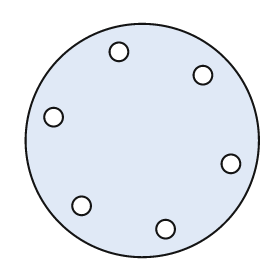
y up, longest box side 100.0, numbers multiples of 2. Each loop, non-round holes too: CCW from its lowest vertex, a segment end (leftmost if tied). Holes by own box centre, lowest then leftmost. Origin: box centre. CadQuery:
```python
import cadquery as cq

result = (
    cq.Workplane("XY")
    .moveTo(0.0, 0.0)
    .circle(50.0)
    .moveTo(10.0, -38.0)
    .circle(4.0)
    .moveTo(-26.0, -28.0)
    .circle(4.0)
    .moveTo(38.0, -10.0)
    .circle(4.0)
    .moveTo(-38.0, 10.0)
    .circle(4.0)
    .moveTo(26.0, 28.0)
    .circle(4.0)
    .moveTo(-10.0, 38.0)
    .circle(4.0)
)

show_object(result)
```